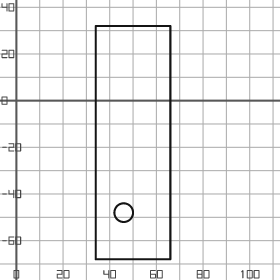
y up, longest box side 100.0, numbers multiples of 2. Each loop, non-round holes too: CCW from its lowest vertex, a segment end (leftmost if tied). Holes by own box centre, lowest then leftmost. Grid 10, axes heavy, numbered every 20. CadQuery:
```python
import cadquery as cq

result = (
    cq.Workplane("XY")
    .moveTo(34.0, -68.0)
    .lineTo(66.0, -68.0)
    .lineTo(66.0, 32.0)
    .lineTo(34.0, 32.0)
    .close()
    .moveTo(46.0, -48.0)
    .circle(4.0)
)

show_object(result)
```